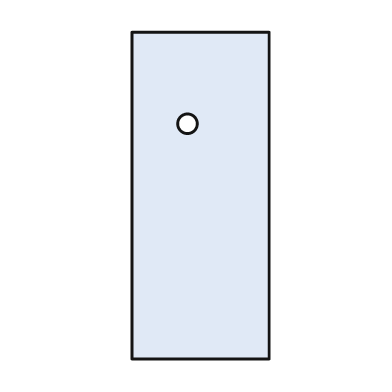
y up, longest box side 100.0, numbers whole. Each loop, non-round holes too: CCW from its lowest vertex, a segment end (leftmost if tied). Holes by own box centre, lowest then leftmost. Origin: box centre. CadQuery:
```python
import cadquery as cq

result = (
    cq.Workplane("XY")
    .moveTo(-21.0, -50.0)
    .lineTo(21.0, -50.0)
    .lineTo(21.0, 50.0)
    .lineTo(-21.0, 50.0)
    .close()
    .moveTo(-4.0, 22.0)
    .circle(3.0)
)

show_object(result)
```